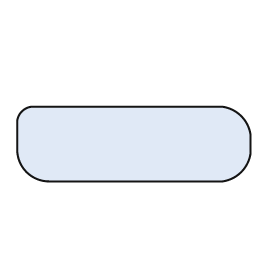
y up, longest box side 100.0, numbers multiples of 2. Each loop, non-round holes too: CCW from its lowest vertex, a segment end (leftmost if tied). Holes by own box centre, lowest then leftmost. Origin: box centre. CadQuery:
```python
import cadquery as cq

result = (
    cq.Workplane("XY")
    .moveTo(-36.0, -16.0)
    .lineTo(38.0, -16.0)
    .threePointArc((46.0, -12.0), (50.0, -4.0))
    .lineTo(50.0, 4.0)
    .threePointArc((46.0, 12.0), (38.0, 16.0))
    .lineTo(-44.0, 16.0)
    .threePointArc((-48.0, 14.0), (-50.0, 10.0))
    .lineTo(-50.0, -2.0)
    .threePointArc((-46.0, -12.0), (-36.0, -16.0))
    .close()
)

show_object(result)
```